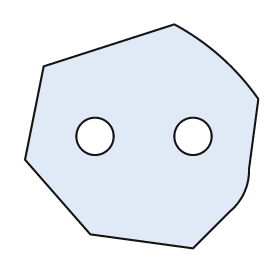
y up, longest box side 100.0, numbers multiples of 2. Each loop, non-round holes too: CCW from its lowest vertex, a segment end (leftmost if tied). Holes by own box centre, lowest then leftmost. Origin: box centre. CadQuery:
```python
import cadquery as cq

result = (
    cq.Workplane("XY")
    .moveTo(22.0, -48.0)
    .lineTo(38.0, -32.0)
    .threePointArc((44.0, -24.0), (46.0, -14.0))
    .lineTo(50.0, 16.0)
    .threePointArc((34.0, 34.0), (14.0, 48.0))
    .lineTo(-42.0, 30.0)
    .lineTo(-50.0, -10.0)
    .lineTo(-22.0, -42.0)
    .close()
    .moveTo(-20.0, 0.0)
    .circle(8.0)
    .moveTo(22.0, 0.0)
    .circle(8.0)
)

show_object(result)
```